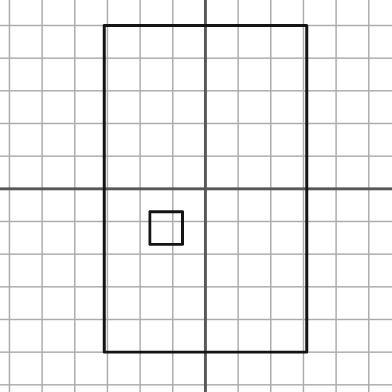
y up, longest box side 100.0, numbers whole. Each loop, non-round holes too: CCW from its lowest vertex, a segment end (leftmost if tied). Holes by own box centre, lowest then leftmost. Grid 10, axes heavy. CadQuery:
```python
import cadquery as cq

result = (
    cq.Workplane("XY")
    .moveTo(-31.0, -50.0)
    .lineTo(31.0, -50.0)
    .lineTo(31.0, 50.0)
    .lineTo(-31.0, 50.0)
    .close()
    .moveTo(-17.0, -17.0)
    .lineTo(-7.0, -17.0)
    .lineTo(-7.0, -7.0)
    .lineTo(-17.0, -7.0)
    .close()
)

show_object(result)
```